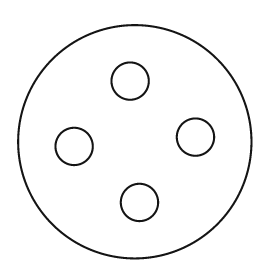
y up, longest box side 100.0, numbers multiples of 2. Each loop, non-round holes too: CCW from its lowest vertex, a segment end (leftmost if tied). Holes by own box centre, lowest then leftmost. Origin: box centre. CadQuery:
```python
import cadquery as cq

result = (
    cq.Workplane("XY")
    .moveTo(0.0, 0.0)
    .circle(50.0)
    .moveTo(2.0, -26.0)
    .circle(8.0)
    .moveTo(-26.0, -2.0)
    .circle(8.0)
    .moveTo(26.0, 2.0)
    .circle(8.0)
    .moveTo(-2.0, 26.0)
    .circle(8.0)
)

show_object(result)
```